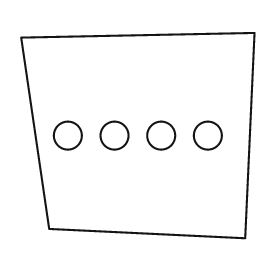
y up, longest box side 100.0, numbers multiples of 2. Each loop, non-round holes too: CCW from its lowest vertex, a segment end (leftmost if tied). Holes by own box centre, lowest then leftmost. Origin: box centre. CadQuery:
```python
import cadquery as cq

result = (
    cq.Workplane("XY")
    .moveTo(46.0, -44.0)
    .lineTo(50.0, 44.0)
    .lineTo(-50.0, 42.0)
    .lineTo(-38.0, -40.0)
    .close()
    .moveTo(-30.0, 0.0)
    .circle(6.0)
    .moveTo(-10.0, 0.0)
    .circle(6.0)
    .moveTo(10.0, 0.0)
    .circle(6.0)
    .moveTo(30.0, 0.0)
    .circle(6.0)
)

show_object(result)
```